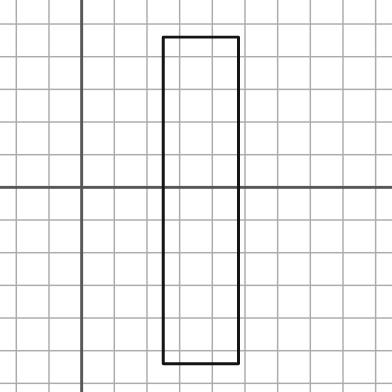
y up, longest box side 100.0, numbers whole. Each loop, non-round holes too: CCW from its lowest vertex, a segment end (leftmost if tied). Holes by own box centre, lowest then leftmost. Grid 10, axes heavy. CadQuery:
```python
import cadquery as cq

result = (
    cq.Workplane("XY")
    .moveTo(25.0, -54.0)
    .lineTo(48.0, -54.0)
    .lineTo(48.0, 46.0)
    .lineTo(25.0, 46.0)
    .close()
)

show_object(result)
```